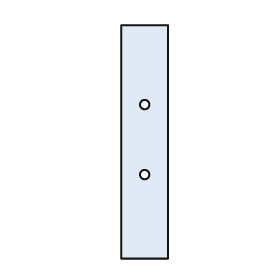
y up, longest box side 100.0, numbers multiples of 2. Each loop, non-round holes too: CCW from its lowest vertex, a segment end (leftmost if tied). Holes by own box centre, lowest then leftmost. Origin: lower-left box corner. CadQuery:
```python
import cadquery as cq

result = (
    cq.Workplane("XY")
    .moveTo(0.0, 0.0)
    .lineTo(20.0, 0.0)
    .lineTo(20.0, 100.0)
    .lineTo(0.0, 100.0)
    .close()
    .moveTo(10.0, 36.0)
    .circle(2.0)
    .moveTo(10.0, 66.0)
    .circle(2.0)
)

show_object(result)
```